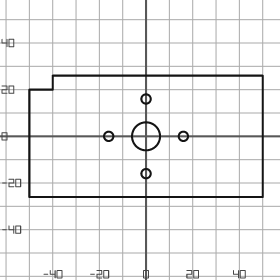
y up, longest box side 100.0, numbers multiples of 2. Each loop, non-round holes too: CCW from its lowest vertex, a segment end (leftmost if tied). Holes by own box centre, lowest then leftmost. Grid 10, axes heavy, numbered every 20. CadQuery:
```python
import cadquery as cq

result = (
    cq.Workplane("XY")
    .moveTo(-50.0, -26.0)
    .lineTo(50.0, -26.0)
    .lineTo(50.0, 26.0)
    .lineTo(-40.0, 26.0)
    .lineTo(-40.0, 20.0)
    .lineTo(-50.0, 20.0)
    .close()
    .moveTo(0.0, -16.0)
    .circle(2.0)
    .moveTo(-16.0, 0.0)
    .circle(2.0)
    .moveTo(0.0, 0.0)
    .circle(6.0)
    .moveTo(16.0, 0.0)
    .circle(2.0)
    .moveTo(0.0, 16.0)
    .circle(2.0)
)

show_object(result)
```